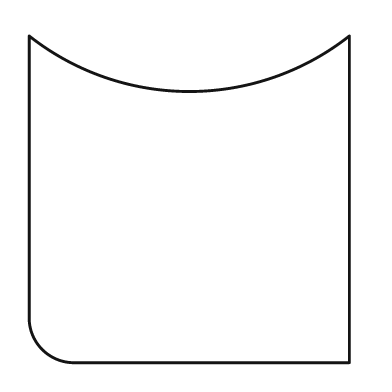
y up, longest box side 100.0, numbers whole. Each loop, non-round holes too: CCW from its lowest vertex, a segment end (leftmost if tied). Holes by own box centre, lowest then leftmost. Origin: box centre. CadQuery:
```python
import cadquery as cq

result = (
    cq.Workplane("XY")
    .moveTo(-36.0, -50.0)
    .lineTo(49.0, -50.0)
    .lineTo(49.0, 50.0)
    .threePointArc((0.0, 33.0), (-49.0, 50.0))
    .lineTo(-49.0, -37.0)
    .threePointArc((-45.0, -46.0), (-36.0, -50.0))
    .close()
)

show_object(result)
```